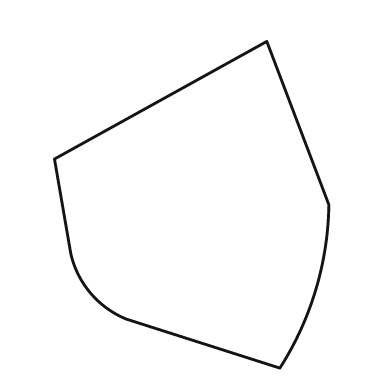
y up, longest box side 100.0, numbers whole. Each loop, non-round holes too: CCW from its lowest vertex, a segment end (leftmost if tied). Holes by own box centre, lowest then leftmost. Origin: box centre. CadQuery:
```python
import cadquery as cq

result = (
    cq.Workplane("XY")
    .moveTo(27.0, -50.0)
    .threePointArc((38.0, -26.0), (42.0, 0.0))
    .lineTo(23.0, 50.0)
    .lineTo(-42.0, 14.0)
    .lineTo(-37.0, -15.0)
    .threePointArc((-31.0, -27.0), (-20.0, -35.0))
    .close()
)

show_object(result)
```